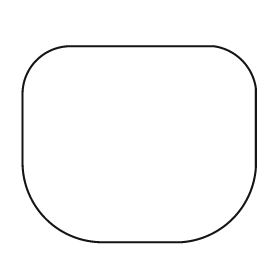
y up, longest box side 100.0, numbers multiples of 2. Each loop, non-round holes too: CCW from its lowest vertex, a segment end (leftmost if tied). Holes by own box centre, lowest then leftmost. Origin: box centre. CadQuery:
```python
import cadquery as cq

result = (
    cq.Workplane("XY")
    .moveTo(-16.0, -42.0)
    .lineTo(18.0, -42.0)
    .threePointArc((40.0, -32.0), (50.0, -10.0))
    .lineTo(50.0, 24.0)
    .threePointArc((44.0, 36.0), (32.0, 42.0))
    .lineTo(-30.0, 42.0)
    .threePointArc((-44.0, 36.0), (-50.0, 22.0))
    .lineTo(-50.0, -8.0)
    .threePointArc((-40.0, -32.0), (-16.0, -42.0))
    .close()
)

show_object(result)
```